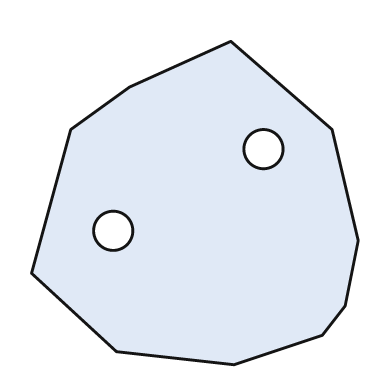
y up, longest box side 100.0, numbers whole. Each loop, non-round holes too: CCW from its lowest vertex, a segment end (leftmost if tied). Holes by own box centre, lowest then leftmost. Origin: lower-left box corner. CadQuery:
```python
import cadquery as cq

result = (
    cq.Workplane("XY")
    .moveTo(62.0, 0.0)
    .lineTo(89.0, 9.0)
    .lineTo(96.0, 18.0)
    .lineTo(100.0, 38.0)
    .lineTo(92.0, 72.0)
    .lineTo(61.0, 99.0)
    .lineTo(30.0, 85.0)
    .lineTo(12.0, 72.0)
    .lineTo(0.0, 28.0)
    .lineTo(26.0, 4.0)
    .close()
    .moveTo(25.0, 41.0)
    .circle(6.0)
    .moveTo(71.0, 66.0)
    .circle(6.0)
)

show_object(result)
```